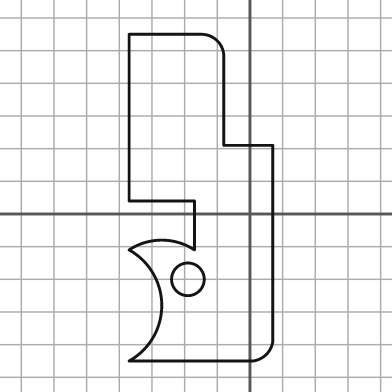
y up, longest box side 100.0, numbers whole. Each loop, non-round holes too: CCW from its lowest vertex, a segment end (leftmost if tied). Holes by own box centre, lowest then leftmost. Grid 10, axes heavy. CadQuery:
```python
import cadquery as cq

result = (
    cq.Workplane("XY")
    .moveTo(-37.0, -45.0)
    .lineTo(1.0, -45.0)
    .threePointArc((5.0, -43.0), (7.0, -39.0))
    .lineTo(7.0, 21.0)
    .lineTo(-8.0, 21.0)
    .lineTo(-8.0, 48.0)
    .threePointArc((-10.0, 53.0), (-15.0, 55.0))
    .lineTo(-37.0, 55.0)
    .lineTo(-37.0, 4.0)
    .lineTo(-17.0, 4.0)
    .lineTo(-17.0, -11.0)
    .threePointArc((-27.0, -8.0), (-37.0, -11.0))
    .threePointArc((-27.0, -28.0), (-37.0, -45.0))
    .close()
    .moveTo(-19.0, -20.0)
    .circle(5.0)
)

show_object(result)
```